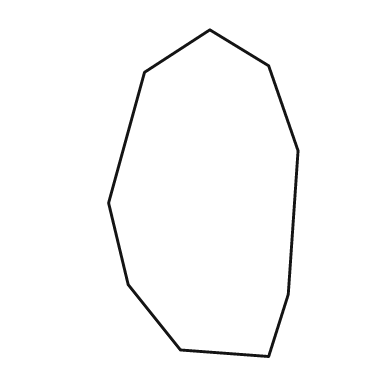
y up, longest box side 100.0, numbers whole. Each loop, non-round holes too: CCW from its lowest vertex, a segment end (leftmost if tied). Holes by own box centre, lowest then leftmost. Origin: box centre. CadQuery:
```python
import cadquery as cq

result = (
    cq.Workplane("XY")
    .moveTo(20.0, -50.0)
    .lineTo(26.0, -31.0)
    .lineTo(29.0, 13.0)
    .lineTo(20.0, 39.0)
    .lineTo(2.0, 50.0)
    .lineTo(-18.0, 37.0)
    .lineTo(-29.0, -3.0)
    .lineTo(-23.0, -28.0)
    .lineTo(-7.0, -48.0)
    .close()
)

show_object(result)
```